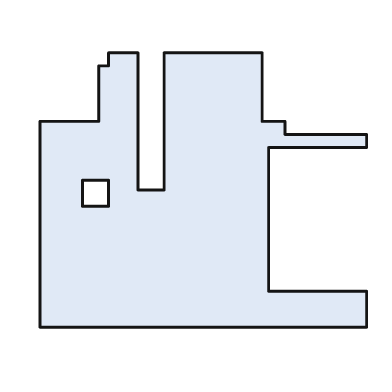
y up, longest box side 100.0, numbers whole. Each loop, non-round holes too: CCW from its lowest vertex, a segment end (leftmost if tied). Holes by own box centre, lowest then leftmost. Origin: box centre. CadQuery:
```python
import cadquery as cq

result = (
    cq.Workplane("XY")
    .moveTo(-50.0, -42.0)
    .lineTo(50.0, -42.0)
    .lineTo(50.0, -31.0)
    .lineTo(20.0, -31.0)
    .lineTo(20.0, 13.0)
    .lineTo(50.0, 13.0)
    .lineTo(50.0, 17.0)
    .lineTo(25.0, 17.0)
    .lineTo(25.0, 21.0)
    .lineTo(18.0, 21.0)
    .lineTo(18.0, 42.0)
    .lineTo(-12.0, 42.0)
    .lineTo(-12.0, 0.0)
    .lineTo(-20.0, 0.0)
    .lineTo(-20.0, 42.0)
    .lineTo(-29.0, 42.0)
    .lineTo(-29.0, 38.0)
    .lineTo(-32.0, 38.0)
    .lineTo(-32.0, 21.0)
    .lineTo(-50.0, 21.0)
    .close()
    .moveTo(-37.0, -5.0)
    .lineTo(-29.0, -5.0)
    .lineTo(-29.0, 3.0)
    .lineTo(-37.0, 3.0)
    .close()
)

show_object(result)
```